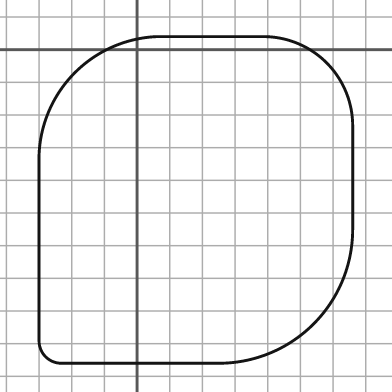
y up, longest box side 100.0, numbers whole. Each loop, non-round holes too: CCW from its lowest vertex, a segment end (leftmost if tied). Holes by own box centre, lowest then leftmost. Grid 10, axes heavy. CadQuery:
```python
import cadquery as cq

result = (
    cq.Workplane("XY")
    .moveTo(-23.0, -96.0)
    .lineTo(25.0, -96.0)
    .threePointArc((54.0, -84.0), (66.0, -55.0))
    .lineTo(66.0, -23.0)
    .threePointArc((58.0, -4.0), (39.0, 4.0))
    .lineTo(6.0, 4.0)
    .threePointArc((-19.0, -7.0), (-30.0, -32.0))
    .lineTo(-30.0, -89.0)
    .threePointArc((-28.0, -94.0), (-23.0, -96.0))
    .close()
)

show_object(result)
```